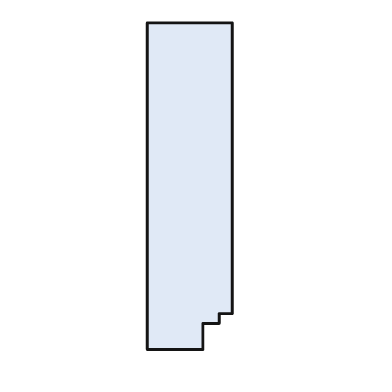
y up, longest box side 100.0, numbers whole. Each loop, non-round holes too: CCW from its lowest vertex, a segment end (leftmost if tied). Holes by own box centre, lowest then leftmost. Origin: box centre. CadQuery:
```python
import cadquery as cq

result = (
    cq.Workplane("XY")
    .moveTo(-13.0, -50.0)
    .lineTo(4.0, -50.0)
    .lineTo(4.0, -42.0)
    .lineTo(9.0, -42.0)
    .lineTo(9.0, -39.0)
    .lineTo(13.0, -39.0)
    .lineTo(13.0, 50.0)
    .lineTo(-13.0, 50.0)
    .close()
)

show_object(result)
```